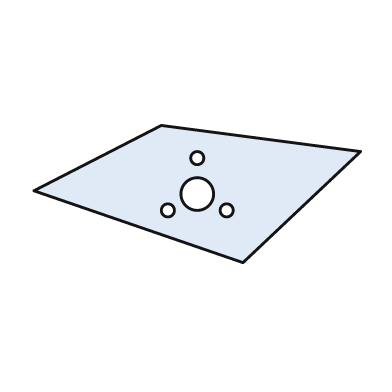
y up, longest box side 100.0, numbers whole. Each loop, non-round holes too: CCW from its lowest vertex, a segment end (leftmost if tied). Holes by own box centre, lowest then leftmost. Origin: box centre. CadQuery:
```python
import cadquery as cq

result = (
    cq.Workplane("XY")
    .moveTo(14.0, -21.0)
    .lineTo(50.0, 13.0)
    .lineTo(-11.0, 21.0)
    .lineTo(-50.0, 1.0)
    .close()
    .moveTo(-9.0, -5.0)
    .circle(2.0)
    .moveTo(9.0, -5.0)
    .circle(2.0)
    .moveTo(0.0, 0.0)
    .circle(5.0)
    .moveTo(0.0, 11.0)
    .circle(2.0)
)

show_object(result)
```